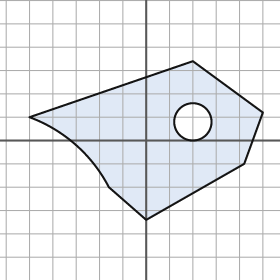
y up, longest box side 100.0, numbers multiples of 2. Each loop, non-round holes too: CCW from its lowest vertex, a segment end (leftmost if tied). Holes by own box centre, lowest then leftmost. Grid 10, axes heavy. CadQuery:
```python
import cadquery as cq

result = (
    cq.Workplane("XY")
    .moveTo(0.0, -34.0)
    .lineTo(42.0, -10.0)
    .lineTo(50.0, 12.0)
    .lineTo(20.0, 34.0)
    .lineTo(-50.0, 10.0)
    .threePointArc((-30.0, -2.0), (-16.0, -20.0))
    .close()
    .moveTo(20.0, 8.0)
    .circle(8.0)
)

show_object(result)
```